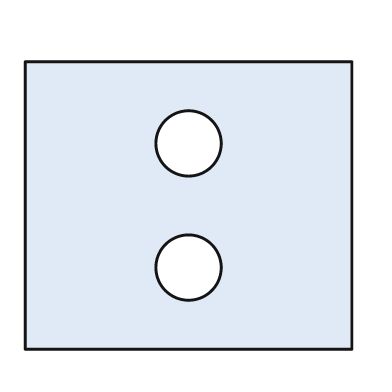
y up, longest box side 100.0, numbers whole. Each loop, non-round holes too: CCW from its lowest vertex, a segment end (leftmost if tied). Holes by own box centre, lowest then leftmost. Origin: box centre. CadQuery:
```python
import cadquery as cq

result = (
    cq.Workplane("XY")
    .moveTo(-50.0, -44.0)
    .lineTo(50.0, -44.0)
    .lineTo(50.0, 44.0)
    .lineTo(-50.0, 44.0)
    .close()
    .moveTo(0.0, -19.0)
    .circle(10.0)
    .moveTo(0.0, 19.0)
    .circle(10.0)
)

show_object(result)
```